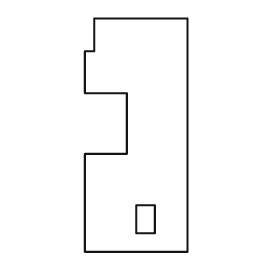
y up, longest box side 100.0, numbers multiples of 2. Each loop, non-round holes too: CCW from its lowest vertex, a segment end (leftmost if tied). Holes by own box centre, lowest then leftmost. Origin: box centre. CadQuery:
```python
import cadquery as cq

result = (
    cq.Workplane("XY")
    .moveTo(-22.0, -50.0)
    .lineTo(22.0, -50.0)
    .lineTo(22.0, 50.0)
    .lineTo(-18.0, 50.0)
    .lineTo(-18.0, 36.0)
    .lineTo(-22.0, 36.0)
    .lineTo(-22.0, 18.0)
    .lineTo(-4.0, 18.0)
    .lineTo(-4.0, -8.0)
    .lineTo(-22.0, -8.0)
    .close()
    .moveTo(0.0, -42.0)
    .lineTo(8.0, -42.0)
    .lineTo(8.0, -30.0)
    .lineTo(0.0, -30.0)
    .close()
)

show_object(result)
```